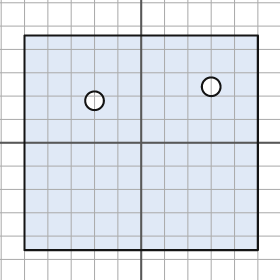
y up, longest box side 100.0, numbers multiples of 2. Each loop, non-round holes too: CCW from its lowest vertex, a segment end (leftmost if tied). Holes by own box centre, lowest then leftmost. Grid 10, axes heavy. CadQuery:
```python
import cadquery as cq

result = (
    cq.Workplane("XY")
    .moveTo(-50.0, -46.0)
    .lineTo(50.0, -46.0)
    .lineTo(50.0, 46.0)
    .lineTo(-50.0, 46.0)
    .close()
    .moveTo(-20.0, 18.0)
    .circle(4.0)
    .moveTo(30.0, 24.0)
    .circle(4.0)
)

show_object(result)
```